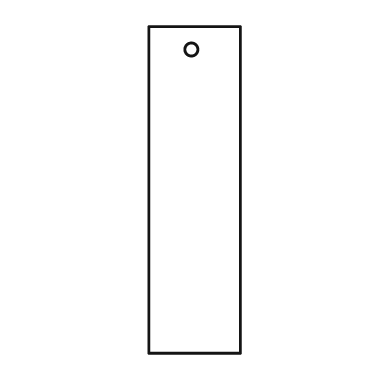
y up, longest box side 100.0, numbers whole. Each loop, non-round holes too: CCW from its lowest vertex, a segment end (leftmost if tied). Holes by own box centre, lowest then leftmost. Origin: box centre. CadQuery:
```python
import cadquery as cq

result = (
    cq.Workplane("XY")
    .moveTo(-14.0, -50.0)
    .lineTo(14.0, -50.0)
    .lineTo(14.0, 50.0)
    .lineTo(-14.0, 50.0)
    .close()
    .moveTo(-1.0, 43.0)
    .circle(2.0)
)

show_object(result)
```